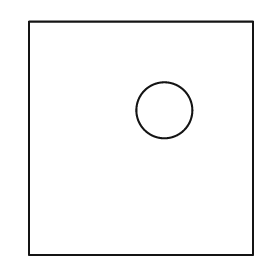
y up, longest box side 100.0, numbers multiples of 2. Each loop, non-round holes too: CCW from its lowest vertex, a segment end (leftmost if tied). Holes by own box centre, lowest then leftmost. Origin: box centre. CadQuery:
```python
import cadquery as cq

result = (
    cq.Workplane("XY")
    .moveTo(-48.0, -50.0)
    .lineTo(48.0, -50.0)
    .lineTo(48.0, 50.0)
    .lineTo(-48.0, 50.0)
    .close()
    .moveTo(10.0, 12.0)
    .circle(12.0)
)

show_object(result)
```